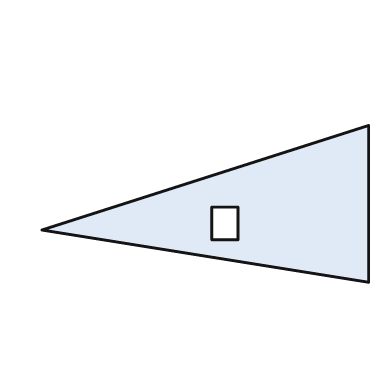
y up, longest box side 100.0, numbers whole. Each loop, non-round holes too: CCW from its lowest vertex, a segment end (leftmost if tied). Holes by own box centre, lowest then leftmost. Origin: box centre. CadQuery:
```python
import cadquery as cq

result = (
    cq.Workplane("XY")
    .moveTo(50.0, -24.0)
    .lineTo(50.0, 24.0)
    .lineTo(-50.0, -8.0)
    .close()
    .moveTo(2.0, -11.0)
    .lineTo(10.0, -11.0)
    .lineTo(10.0, -1.0)
    .lineTo(2.0, -1.0)
    .close()
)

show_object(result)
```